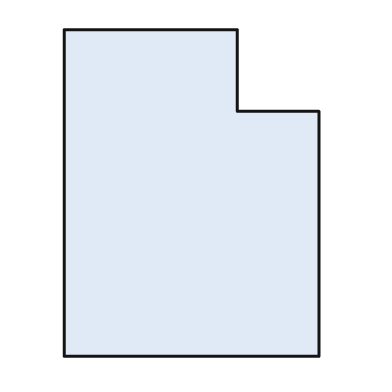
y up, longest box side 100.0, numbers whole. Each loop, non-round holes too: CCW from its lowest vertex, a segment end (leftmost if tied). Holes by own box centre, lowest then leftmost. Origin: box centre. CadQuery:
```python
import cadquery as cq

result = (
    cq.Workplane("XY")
    .moveTo(-39.0, -50.0)
    .lineTo(39.0, -50.0)
    .lineTo(39.0, 25.0)
    .lineTo(14.0, 25.0)
    .lineTo(14.0, 50.0)
    .lineTo(-39.0, 50.0)
    .close()
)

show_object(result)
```